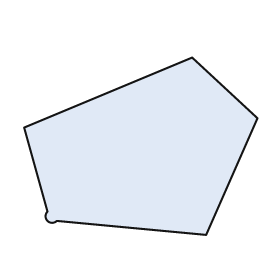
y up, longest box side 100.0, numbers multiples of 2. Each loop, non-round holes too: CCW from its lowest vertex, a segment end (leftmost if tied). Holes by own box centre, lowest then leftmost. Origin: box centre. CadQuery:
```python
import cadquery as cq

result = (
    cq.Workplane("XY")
    .moveTo(28.0, -38.0)
    .lineTo(50.0, 12.0)
    .lineTo(22.0, 38.0)
    .lineTo(-50.0, 8.0)
    .lineTo(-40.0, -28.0)
    .threePointArc((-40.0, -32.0), (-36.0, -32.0))
    .close()
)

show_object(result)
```